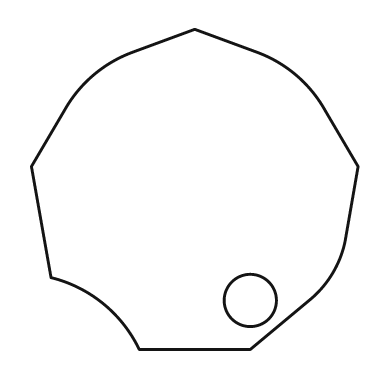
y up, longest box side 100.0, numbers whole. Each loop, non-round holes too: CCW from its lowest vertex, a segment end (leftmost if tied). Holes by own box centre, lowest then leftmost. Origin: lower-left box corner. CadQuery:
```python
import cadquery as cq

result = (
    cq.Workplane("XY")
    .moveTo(33.0, 0.0)
    .lineTo(67.0, 0.0)
    .lineTo(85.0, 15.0)
    .threePointArc((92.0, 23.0), (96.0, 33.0))
    .lineTo(100.0, 56.0)
    .lineTo(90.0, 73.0)
    .threePointArc((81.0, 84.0), (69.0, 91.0))
    .lineTo(50.0, 98.0)
    .lineTo(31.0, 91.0)
    .threePointArc((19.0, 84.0), (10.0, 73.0))
    .lineTo(0.0, 56.0)
    .lineTo(6.0, 22.0)
    .threePointArc((22.0, 14.0), (33.0, 0.0))
    .close()
    .moveTo(67.0, 15.0)
    .circle(8.0)
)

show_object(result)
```